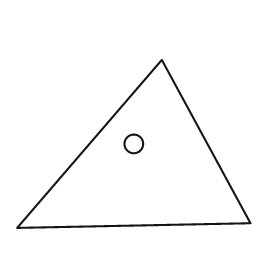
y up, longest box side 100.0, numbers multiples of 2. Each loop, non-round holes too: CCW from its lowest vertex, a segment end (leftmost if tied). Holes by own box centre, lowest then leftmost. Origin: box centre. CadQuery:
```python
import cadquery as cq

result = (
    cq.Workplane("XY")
    .moveTo(-50.0, -36.0)
    .lineTo(50.0, -34.0)
    .lineTo(12.0, 36.0)
    .close()
    .moveTo(0.0, 0.0)
    .circle(4.0)
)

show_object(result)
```